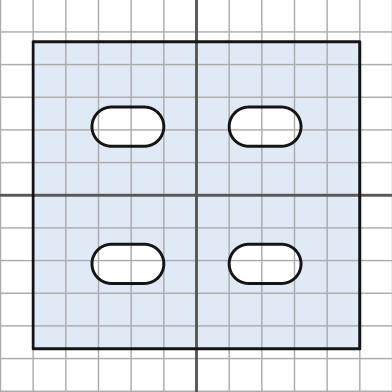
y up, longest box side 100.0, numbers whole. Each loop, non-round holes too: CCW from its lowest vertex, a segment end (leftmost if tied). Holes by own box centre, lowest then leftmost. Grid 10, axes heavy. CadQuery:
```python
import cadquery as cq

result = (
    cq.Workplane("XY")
    .moveTo(-50.0, -47.0)
    .lineTo(50.0, -47.0)
    .lineTo(50.0, 47.0)
    .lineTo(-50.0, 47.0)
    .close()
    .moveTo(-26.0, -27.0)
    .lineTo(-16.0, -27.0)
    .threePointArc((-10.0, -21.0), (-16.0, -15.0))
    .lineTo(-26.0, -15.0)
    .threePointArc((-32.0, -21.0), (-26.0, -27.0))
    .close()
    .moveTo(16.0, -27.0)
    .lineTo(26.0, -27.0)
    .threePointArc((32.0, -21.0), (26.0, -15.0))
    .lineTo(16.0, -15.0)
    .threePointArc((10.0, -21.0), (16.0, -27.0))
    .close()
    .moveTo(-26.0, 15.0)
    .lineTo(-16.0, 15.0)
    .threePointArc((-10.0, 21.0), (-16.0, 27.0))
    .lineTo(-26.0, 27.0)
    .threePointArc((-32.0, 21.0), (-26.0, 15.0))
    .close()
    .moveTo(16.0, 15.0)
    .lineTo(26.0, 15.0)
    .threePointArc((32.0, 21.0), (26.0, 27.0))
    .lineTo(16.0, 27.0)
    .threePointArc((10.0, 21.0), (16.0, 15.0))
    .close()
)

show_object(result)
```